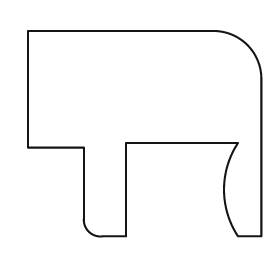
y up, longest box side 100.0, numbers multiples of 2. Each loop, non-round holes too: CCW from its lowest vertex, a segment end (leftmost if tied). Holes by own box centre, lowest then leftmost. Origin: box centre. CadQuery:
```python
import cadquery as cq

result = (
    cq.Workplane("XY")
    .moveTo(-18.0, -44.0)
    .lineTo(-8.0, -44.0)
    .lineTo(-8.0, -4.0)
    .lineTo(40.0, -4.0)
    .threePointArc((34.0, -24.0), (40.0, -44.0))
    .lineTo(50.0, -44.0)
    .lineTo(50.0, 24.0)
    .threePointArc((44.0, 38.0), (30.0, 44.0))
    .lineTo(-50.0, 44.0)
    .lineTo(-50.0, -6.0)
    .lineTo(-26.0, -6.0)
    .lineTo(-26.0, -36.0)
    .threePointArc((-24.0, -42.0), (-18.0, -44.0))
    .close()
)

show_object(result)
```